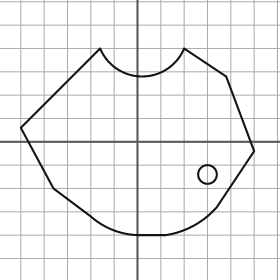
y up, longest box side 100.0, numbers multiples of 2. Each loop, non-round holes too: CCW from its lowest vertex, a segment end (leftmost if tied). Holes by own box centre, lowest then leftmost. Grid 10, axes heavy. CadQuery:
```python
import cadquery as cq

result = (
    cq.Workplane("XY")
    .moveTo(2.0, -40.0)
    .lineTo(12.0, -40.0)
    .threePointArc((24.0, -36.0), (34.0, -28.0))
    .lineTo(50.0, -4.0)
    .lineTo(38.0, 28.0)
    .lineTo(20.0, 40.0)
    .threePointArc((2.0, 28.0), (-16.0, 40.0))
    .lineTo(-50.0, 6.0)
    .lineTo(-36.0, -20.0)
    .lineTo(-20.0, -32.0)
    .threePointArc((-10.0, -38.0), (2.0, -40.0))
    .close()
    .moveTo(30.0, -14.0)
    .circle(4.0)
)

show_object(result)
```